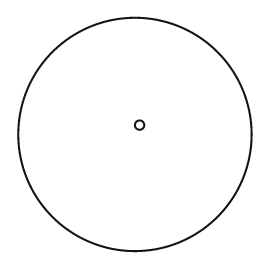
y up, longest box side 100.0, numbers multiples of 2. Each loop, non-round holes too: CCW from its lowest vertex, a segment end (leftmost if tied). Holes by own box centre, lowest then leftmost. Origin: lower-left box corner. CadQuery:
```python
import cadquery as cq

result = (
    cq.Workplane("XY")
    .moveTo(50.0, 50.0)
    .circle(50.0)
    .moveTo(52.0, 54.0)
    .circle(2.0)
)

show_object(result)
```